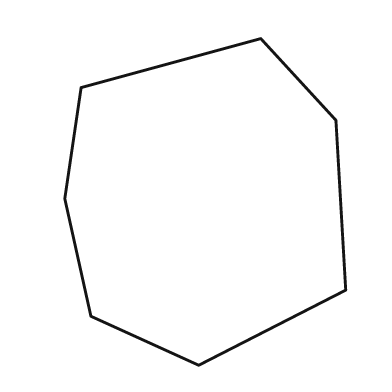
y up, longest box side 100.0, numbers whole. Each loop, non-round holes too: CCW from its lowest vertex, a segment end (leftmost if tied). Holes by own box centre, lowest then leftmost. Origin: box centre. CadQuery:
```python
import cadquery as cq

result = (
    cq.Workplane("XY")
    .moveTo(-2.0, -50.0)
    .lineTo(43.0, -27.0)
    .lineTo(40.0, 25.0)
    .lineTo(17.0, 50.0)
    .lineTo(-38.0, 35.0)
    .lineTo(-43.0, 1.0)
    .lineTo(-35.0, -35.0)
    .close()
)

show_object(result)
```